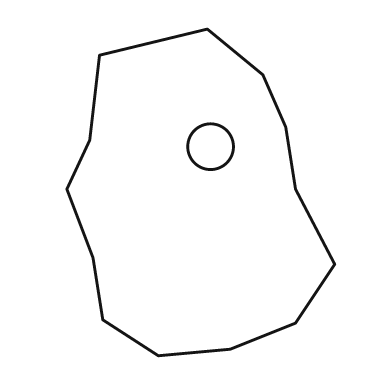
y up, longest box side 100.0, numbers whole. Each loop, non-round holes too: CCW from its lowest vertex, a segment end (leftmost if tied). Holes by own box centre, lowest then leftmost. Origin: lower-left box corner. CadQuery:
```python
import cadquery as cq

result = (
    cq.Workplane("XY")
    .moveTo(28.0, 0.0)
    .lineTo(50.0, 2.0)
    .lineTo(70.0, 10.0)
    .lineTo(82.0, 28.0)
    .lineTo(70.0, 51.0)
    .lineTo(67.0, 70.0)
    .lineTo(60.0, 86.0)
    .lineTo(43.0, 100.0)
    .lineTo(10.0, 92.0)
    .lineTo(7.0, 66.0)
    .lineTo(0.0, 51.0)
    .lineTo(8.0, 30.0)
    .lineTo(11.0, 11.0)
    .close()
    .moveTo(44.0, 64.0)
    .circle(7.0)
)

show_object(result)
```